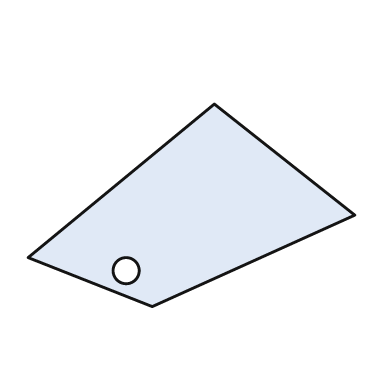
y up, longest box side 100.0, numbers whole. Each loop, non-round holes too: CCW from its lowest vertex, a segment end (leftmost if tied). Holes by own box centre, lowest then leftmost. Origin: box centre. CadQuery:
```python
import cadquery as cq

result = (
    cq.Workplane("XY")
    .moveTo(-12.0, -31.0)
    .lineTo(50.0, -3.0)
    .lineTo(7.0, 31.0)
    .lineTo(-50.0, -16.0)
    .close()
    .moveTo(-20.0, -20.0)
    .circle(4.0)
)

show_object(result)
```